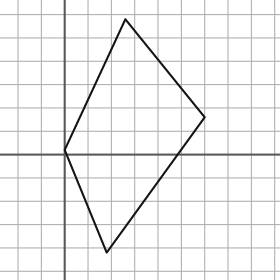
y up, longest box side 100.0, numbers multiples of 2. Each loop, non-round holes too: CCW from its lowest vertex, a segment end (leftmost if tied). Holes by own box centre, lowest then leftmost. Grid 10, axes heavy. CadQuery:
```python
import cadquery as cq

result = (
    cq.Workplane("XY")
    .moveTo(18.0, -42.0)
    .lineTo(60.0, 16.0)
    .lineTo(26.0, 58.0)
    .lineTo(0.0, 2.0)
    .close()
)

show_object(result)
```